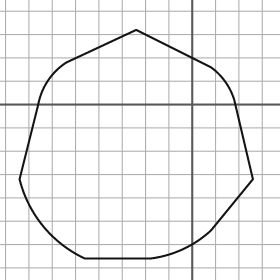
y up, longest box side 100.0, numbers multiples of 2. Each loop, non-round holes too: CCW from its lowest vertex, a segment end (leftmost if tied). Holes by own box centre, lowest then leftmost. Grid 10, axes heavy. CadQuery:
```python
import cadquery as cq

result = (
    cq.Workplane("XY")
    .moveTo(-46.0, -66.0)
    .lineTo(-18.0, -66.0)
    .threePointArc((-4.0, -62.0), (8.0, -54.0))
    .lineTo(26.0, -32.0)
    .lineTo(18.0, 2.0)
    .threePointArc((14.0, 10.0), (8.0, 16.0))
    .lineTo(-24.0, 32.0)
    .lineTo(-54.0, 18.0)
    .threePointArc((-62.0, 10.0), (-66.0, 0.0))
    .lineTo(-74.0, -32.0)
    .threePointArc((-64.0, -52.0), (-46.0, -66.0))
    .close()
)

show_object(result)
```